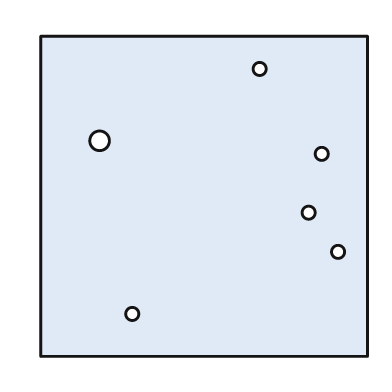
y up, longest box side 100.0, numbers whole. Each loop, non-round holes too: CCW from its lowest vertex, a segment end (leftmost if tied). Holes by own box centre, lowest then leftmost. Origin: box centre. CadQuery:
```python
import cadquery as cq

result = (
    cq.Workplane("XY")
    .moveTo(-50.0, -49.0)
    .lineTo(50.0, -49.0)
    .lineTo(50.0, 49.0)
    .lineTo(-50.0, 49.0)
    .close()
    .moveTo(-22.0, -36.0)
    .circle(2.0)
    .moveTo(41.0, -17.0)
    .circle(2.0)
    .moveTo(32.0, -5.0)
    .circle(2.0)
    .moveTo(36.0, 13.0)
    .circle(2.0)
    .moveTo(-32.0, 17.0)
    .circle(3.0)
    .moveTo(17.0, 39.0)
    .circle(2.0)
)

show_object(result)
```